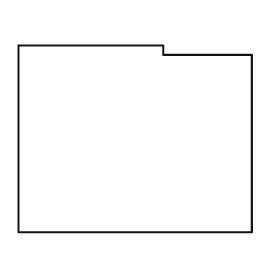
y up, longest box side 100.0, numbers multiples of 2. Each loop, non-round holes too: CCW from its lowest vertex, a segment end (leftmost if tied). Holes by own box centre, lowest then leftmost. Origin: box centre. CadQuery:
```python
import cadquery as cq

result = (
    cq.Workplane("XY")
    .moveTo(-50.0, -40.0)
    .lineTo(50.0, -40.0)
    .lineTo(50.0, 36.0)
    .lineTo(12.0, 36.0)
    .lineTo(12.0, 40.0)
    .lineTo(-50.0, 40.0)
    .close()
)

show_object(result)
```